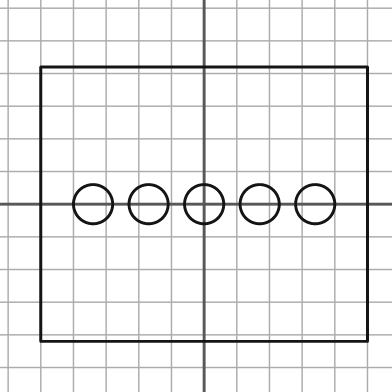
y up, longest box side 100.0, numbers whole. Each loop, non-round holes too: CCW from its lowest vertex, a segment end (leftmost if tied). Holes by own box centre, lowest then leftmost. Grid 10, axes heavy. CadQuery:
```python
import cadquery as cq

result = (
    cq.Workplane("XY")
    .moveTo(-50.0, -42.0)
    .lineTo(50.0, -42.0)
    .lineTo(50.0, 42.0)
    .lineTo(-50.0, 42.0)
    .close()
    .moveTo(-34.0, 0.0)
    .circle(6.0)
    .moveTo(-17.0, 0.0)
    .circle(6.0)
    .moveTo(0.0, 0.0)
    .circle(6.0)
    .moveTo(17.0, 0.0)
    .circle(6.0)
    .moveTo(34.0, 0.0)
    .circle(6.0)
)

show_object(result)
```